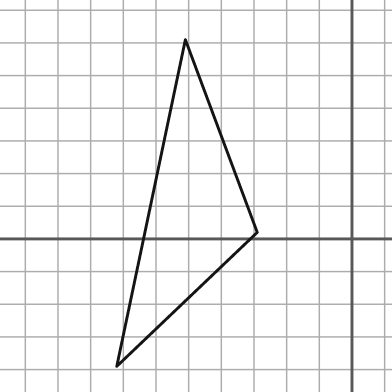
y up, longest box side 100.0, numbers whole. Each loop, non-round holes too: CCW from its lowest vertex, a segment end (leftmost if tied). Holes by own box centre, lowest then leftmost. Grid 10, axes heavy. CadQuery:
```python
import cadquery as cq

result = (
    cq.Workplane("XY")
    .moveTo(-72.0, -39.0)
    .lineTo(-29.0, 2.0)
    .lineTo(-51.0, 61.0)
    .close()
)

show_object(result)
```